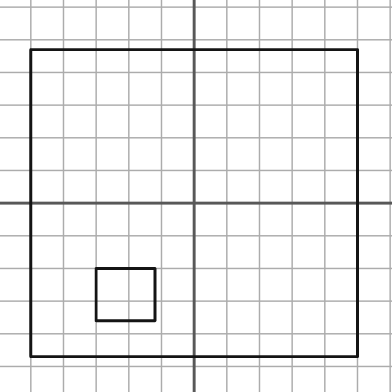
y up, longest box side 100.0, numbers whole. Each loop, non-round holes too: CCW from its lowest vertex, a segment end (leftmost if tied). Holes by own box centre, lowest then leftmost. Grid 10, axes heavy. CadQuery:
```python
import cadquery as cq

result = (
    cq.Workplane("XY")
    .moveTo(-50.0, -47.0)
    .lineTo(50.0, -47.0)
    .lineTo(50.0, 47.0)
    .lineTo(-50.0, 47.0)
    .close()
    .moveTo(-30.0, -36.0)
    .lineTo(-12.0, -36.0)
    .lineTo(-12.0, -20.0)
    .lineTo(-30.0, -20.0)
    .close()
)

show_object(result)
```